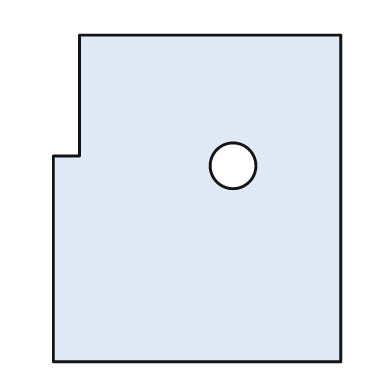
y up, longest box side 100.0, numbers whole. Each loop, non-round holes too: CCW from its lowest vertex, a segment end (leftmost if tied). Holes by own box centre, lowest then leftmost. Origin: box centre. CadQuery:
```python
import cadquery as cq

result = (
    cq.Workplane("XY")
    .moveTo(-44.0, -50.0)
    .lineTo(44.0, -50.0)
    .lineTo(44.0, 50.0)
    .lineTo(-36.0, 50.0)
    .lineTo(-36.0, 13.0)
    .lineTo(-44.0, 13.0)
    .close()
    .moveTo(11.0, 10.0)
    .circle(7.0)
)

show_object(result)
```